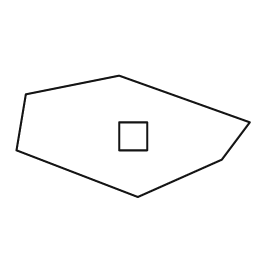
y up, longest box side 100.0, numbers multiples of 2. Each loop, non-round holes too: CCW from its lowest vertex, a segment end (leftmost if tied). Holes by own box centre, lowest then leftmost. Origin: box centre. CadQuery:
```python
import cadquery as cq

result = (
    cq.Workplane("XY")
    .moveTo(2.0, -26.0)
    .lineTo(38.0, -10.0)
    .lineTo(50.0, 6.0)
    .lineTo(-6.0, 26.0)
    .lineTo(-46.0, 18.0)
    .lineTo(-50.0, -6.0)
    .close()
    .moveTo(-6.0, -6.0)
    .lineTo(6.0, -6.0)
    .lineTo(6.0, 6.0)
    .lineTo(-6.0, 6.0)
    .close()
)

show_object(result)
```